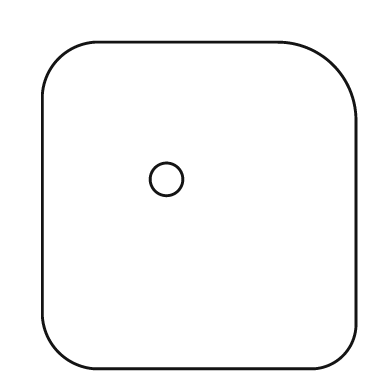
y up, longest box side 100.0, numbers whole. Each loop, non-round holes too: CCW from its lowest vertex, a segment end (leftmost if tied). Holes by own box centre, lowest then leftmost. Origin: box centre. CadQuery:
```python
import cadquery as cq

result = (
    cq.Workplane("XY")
    .moveTo(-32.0, -50.0)
    .lineTo(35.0, -50.0)
    .threePointArc((44.0, -46.0), (48.0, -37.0))
    .lineTo(48.0, 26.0)
    .threePointArc((41.0, 43.0), (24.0, 50.0))
    .lineTo(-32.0, 50.0)
    .threePointArc((-43.0, 45.0), (-48.0, 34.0))
    .lineTo(-48.0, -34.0)
    .threePointArc((-43.0, -45.0), (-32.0, -50.0))
    .close()
    .moveTo(-10.0, 8.0)
    .circle(5.0)
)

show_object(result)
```